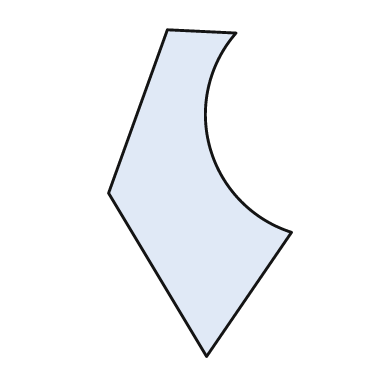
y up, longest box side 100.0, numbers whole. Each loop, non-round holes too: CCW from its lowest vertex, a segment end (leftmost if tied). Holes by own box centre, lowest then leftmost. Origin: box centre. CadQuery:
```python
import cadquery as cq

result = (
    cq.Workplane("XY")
    .moveTo(2.0, -50.0)
    .lineTo(28.0, -12.0)
    .threePointArc((3.0, 14.0), (11.0, 49.0))
    .lineTo(-10.0, 50.0)
    .lineTo(-28.0, 0.0)
    .close()
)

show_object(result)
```